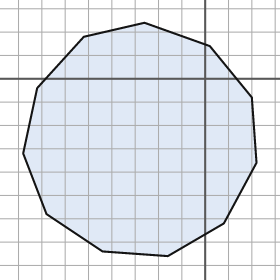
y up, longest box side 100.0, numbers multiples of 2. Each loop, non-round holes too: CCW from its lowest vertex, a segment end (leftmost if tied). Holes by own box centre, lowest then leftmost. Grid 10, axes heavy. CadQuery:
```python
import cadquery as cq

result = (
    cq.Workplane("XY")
    .moveTo(-16.0, -76.0)
    .lineTo(8.0, -62.0)
    .lineTo(22.0, -36.0)
    .lineTo(20.0, -8.0)
    .lineTo(2.0, 14.0)
    .lineTo(-26.0, 24.0)
    .lineTo(-52.0, 18.0)
    .lineTo(-72.0, -4.0)
    .lineTo(-78.0, -32.0)
    .lineTo(-68.0, -58.0)
    .lineTo(-44.0, -74.0)
    .close()
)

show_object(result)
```